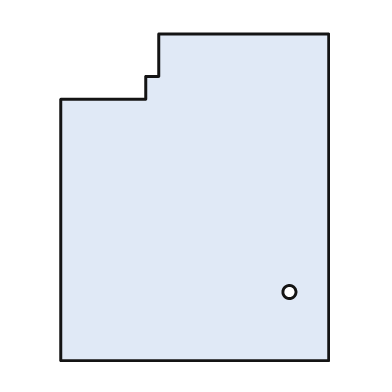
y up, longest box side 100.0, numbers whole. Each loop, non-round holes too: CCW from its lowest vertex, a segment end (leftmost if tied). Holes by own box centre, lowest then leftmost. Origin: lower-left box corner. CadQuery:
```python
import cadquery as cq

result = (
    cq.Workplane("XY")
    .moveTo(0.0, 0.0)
    .lineTo(82.0, 0.0)
    .lineTo(82.0, 100.0)
    .lineTo(30.0, 100.0)
    .lineTo(30.0, 87.0)
    .lineTo(26.0, 87.0)
    .lineTo(26.0, 80.0)
    .lineTo(0.0, 80.0)
    .close()
    .moveTo(70.0, 21.0)
    .circle(2.0)
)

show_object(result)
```